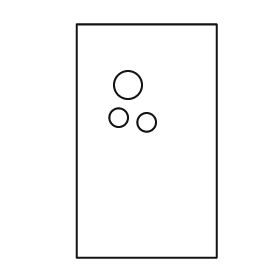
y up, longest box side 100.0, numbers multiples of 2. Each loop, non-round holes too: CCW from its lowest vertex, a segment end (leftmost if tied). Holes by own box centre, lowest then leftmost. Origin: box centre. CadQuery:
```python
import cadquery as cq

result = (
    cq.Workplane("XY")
    .moveTo(-30.0, -50.0)
    .lineTo(30.0, -50.0)
    .lineTo(30.0, 50.0)
    .lineTo(-30.0, 50.0)
    .close()
    .moveTo(0.0, 8.0)
    .circle(4.0)
    .moveTo(-12.0, 10.0)
    .circle(4.0)
    .moveTo(-8.0, 24.0)
    .circle(6.0)
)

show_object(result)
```